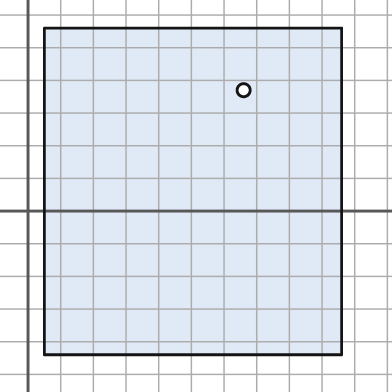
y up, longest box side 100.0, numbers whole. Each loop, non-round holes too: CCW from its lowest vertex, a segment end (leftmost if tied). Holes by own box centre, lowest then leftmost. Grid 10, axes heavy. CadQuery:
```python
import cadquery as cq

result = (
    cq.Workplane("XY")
    .moveTo(5.0, -44.0)
    .lineTo(96.0, -44.0)
    .lineTo(96.0, 56.0)
    .lineTo(5.0, 56.0)
    .close()
    .moveTo(66.0, 37.0)
    .circle(2.0)
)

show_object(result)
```